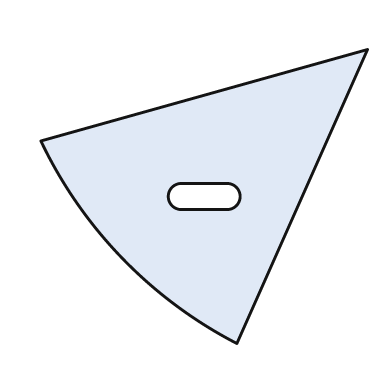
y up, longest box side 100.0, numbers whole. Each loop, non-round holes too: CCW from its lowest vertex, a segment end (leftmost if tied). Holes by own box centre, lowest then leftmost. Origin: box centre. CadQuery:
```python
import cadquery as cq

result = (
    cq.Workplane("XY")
    .moveTo(10.0, -45.0)
    .lineTo(50.0, 45.0)
    .lineTo(-50.0, 17.0)
    .threePointArc((-25.0, -19.0), (10.0, -45.0))
    .close()
    .moveTo(-7.0, -4.0)
    .lineTo(7.0, -4.0)
    .threePointArc((11.0, 0.0), (7.0, 4.0))
    .lineTo(-7.0, 4.0)
    .threePointArc((-11.0, 0.0), (-7.0, -4.0))
    .close()
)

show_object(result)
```